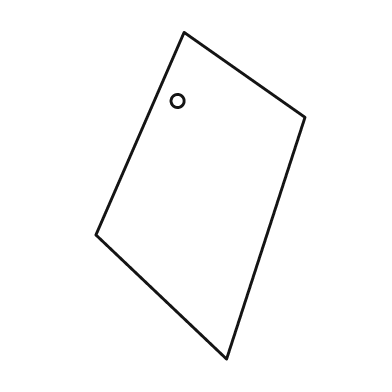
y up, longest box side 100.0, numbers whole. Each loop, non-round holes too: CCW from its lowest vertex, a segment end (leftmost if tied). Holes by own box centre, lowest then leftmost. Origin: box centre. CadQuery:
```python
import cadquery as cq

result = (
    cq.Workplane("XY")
    .moveTo(8.0, -50.0)
    .lineTo(32.0, 24.0)
    .lineTo(-5.0, 50.0)
    .lineTo(-32.0, -12.0)
    .close()
    .moveTo(-7.0, 29.0)
    .circle(2.0)
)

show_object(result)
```